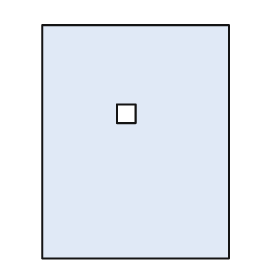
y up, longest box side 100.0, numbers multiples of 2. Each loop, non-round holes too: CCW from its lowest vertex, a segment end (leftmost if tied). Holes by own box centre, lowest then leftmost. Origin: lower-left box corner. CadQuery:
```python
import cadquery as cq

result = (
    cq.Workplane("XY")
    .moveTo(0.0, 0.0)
    .lineTo(80.0, 0.0)
    .lineTo(80.0, 100.0)
    .lineTo(0.0, 100.0)
    .close()
    .moveTo(32.0, 58.0)
    .lineTo(40.0, 58.0)
    .lineTo(40.0, 66.0)
    .lineTo(32.0, 66.0)
    .close()
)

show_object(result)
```